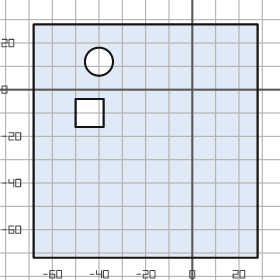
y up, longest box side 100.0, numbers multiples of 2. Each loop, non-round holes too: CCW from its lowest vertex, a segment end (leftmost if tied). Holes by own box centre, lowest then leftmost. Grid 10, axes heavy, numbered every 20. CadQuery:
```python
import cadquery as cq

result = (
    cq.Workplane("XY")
    .moveTo(-68.0, -72.0)
    .lineTo(28.0, -72.0)
    .lineTo(28.0, 28.0)
    .lineTo(-68.0, 28.0)
    .close()
    .moveTo(-50.0, -16.0)
    .lineTo(-38.0, -16.0)
    .lineTo(-38.0, -4.0)
    .lineTo(-50.0, -4.0)
    .close()
    .moveTo(-40.0, 12.0)
    .circle(6.0)
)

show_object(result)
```